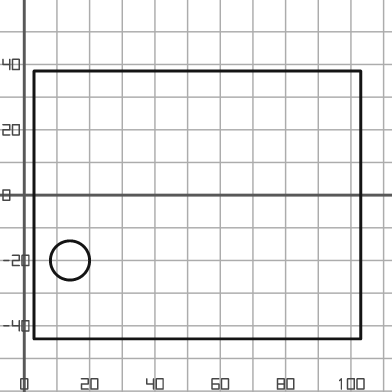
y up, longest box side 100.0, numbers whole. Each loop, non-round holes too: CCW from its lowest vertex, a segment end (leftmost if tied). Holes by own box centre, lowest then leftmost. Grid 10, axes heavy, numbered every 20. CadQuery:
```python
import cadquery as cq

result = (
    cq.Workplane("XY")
    .moveTo(3.0, -44.0)
    .lineTo(103.0, -44.0)
    .lineTo(103.0, 38.0)
    .lineTo(3.0, 38.0)
    .close()
    .moveTo(14.0, -20.0)
    .circle(6.0)
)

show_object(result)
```